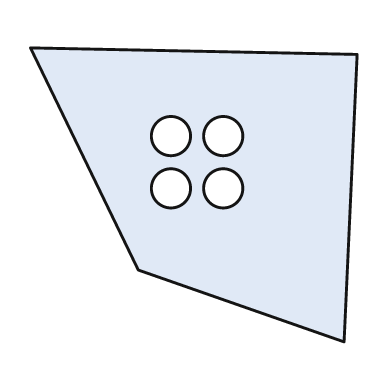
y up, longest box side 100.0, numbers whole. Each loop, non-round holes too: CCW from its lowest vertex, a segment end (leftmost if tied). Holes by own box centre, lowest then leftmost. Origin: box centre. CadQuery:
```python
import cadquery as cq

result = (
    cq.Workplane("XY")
    .moveTo(46.0, -45.0)
    .lineTo(50.0, 43.0)
    .lineTo(-50.0, 45.0)
    .lineTo(-17.0, -23.0)
    .close()
    .moveTo(-7.0, 2.0)
    .circle(6.0)
    .moveTo(9.0, 2.0)
    .circle(6.0)
    .moveTo(-7.0, 18.0)
    .circle(6.0)
    .moveTo(9.0, 18.0)
    .circle(6.0)
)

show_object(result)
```